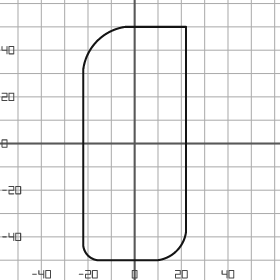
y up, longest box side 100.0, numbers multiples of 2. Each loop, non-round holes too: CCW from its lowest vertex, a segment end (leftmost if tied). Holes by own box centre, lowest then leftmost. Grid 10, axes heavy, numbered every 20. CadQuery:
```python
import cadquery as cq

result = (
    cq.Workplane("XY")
    .moveTo(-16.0, -50.0)
    .lineTo(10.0, -50.0)
    .threePointArc((18.0, -46.0), (22.0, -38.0))
    .lineTo(22.0, 50.0)
    .lineTo(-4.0, 50.0)
    .threePointArc((-16.0, 44.0), (-22.0, 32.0))
    .lineTo(-22.0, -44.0)
    .threePointArc((-20.0, -48.0), (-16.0, -50.0))
    .close()
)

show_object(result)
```